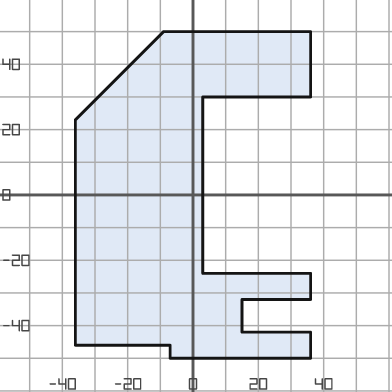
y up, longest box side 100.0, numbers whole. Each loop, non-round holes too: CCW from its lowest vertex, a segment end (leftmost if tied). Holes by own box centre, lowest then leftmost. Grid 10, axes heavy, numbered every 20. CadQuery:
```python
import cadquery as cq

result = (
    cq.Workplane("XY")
    .moveTo(-7.0, -50.0)
    .lineTo(36.0, -50.0)
    .lineTo(36.0, -42.0)
    .lineTo(15.0, -42.0)
    .lineTo(15.0, -32.0)
    .lineTo(36.0, -32.0)
    .lineTo(36.0, -24.0)
    .lineTo(3.0, -24.0)
    .lineTo(3.0, 30.0)
    .lineTo(36.0, 30.0)
    .lineTo(36.0, 50.0)
    .lineTo(-9.0, 50.0)
    .lineTo(-36.0, 23.0)
    .lineTo(-36.0, -46.0)
    .lineTo(-7.0, -46.0)
    .close()
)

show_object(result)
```